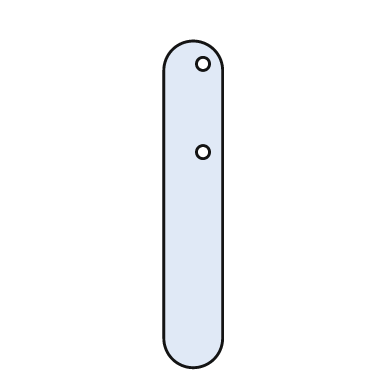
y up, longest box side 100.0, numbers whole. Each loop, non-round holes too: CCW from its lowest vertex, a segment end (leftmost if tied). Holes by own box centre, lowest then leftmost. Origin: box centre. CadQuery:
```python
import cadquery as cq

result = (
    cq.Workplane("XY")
    .moveTo(-9.0, -41.0)
    .threePointArc((0.0, -50.0), (9.0, -41.0))
    .lineTo(9.0, 41.0)
    .threePointArc((0.0, 50.0), (-9.0, 41.0))
    .close()
    .moveTo(3.0, 16.0)
    .circle(2.0)
    .moveTo(3.0, 43.0)
    .circle(2.0)
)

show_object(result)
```